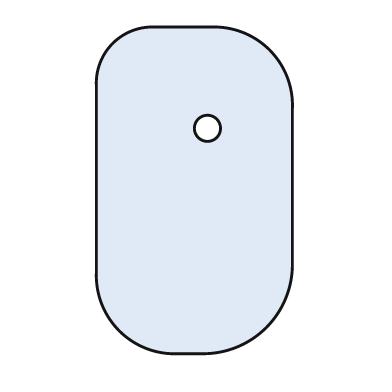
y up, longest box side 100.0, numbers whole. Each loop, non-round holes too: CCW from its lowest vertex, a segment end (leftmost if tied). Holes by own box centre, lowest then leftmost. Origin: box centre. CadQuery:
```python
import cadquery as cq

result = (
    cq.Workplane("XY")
    .moveTo(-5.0, -50.0)
    .lineTo(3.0, -50.0)
    .threePointArc((22.0, -42.0), (30.0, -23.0))
    .lineTo(30.0, 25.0)
    .threePointArc((23.0, 43.0), (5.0, 50.0))
    .lineTo(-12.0, 50.0)
    .threePointArc((-25.0, 45.0), (-30.0, 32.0))
    .lineTo(-30.0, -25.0)
    .threePointArc((-23.0, -43.0), (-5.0, -50.0))
    .close()
    .moveTo(4.0, 19.0)
    .circle(4.0)
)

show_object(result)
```